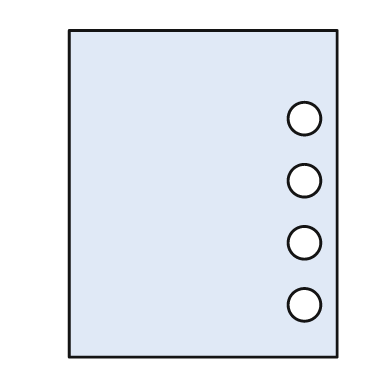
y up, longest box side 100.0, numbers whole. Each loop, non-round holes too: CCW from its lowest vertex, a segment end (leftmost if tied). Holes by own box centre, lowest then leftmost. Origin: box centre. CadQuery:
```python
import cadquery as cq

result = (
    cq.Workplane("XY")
    .moveTo(-41.0, -50.0)
    .lineTo(41.0, -50.0)
    .lineTo(41.0, 50.0)
    .lineTo(-41.0, 50.0)
    .close()
    .moveTo(31.0, -34.0)
    .circle(5.0)
    .moveTo(31.0, -15.0)
    .circle(5.0)
    .moveTo(31.0, 4.0)
    .circle(5.0)
    .moveTo(31.0, 23.0)
    .circle(5.0)
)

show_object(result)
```